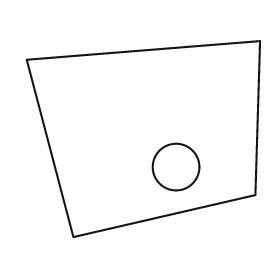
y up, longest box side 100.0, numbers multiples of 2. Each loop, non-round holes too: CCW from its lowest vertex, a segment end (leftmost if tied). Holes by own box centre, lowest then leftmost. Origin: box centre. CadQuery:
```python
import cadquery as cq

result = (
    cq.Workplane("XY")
    .moveTo(-30.0, -42.0)
    .lineTo(48.0, -24.0)
    .lineTo(50.0, 42.0)
    .lineTo(-50.0, 34.0)
    .close()
    .moveTo(14.0, -12.0)
    .circle(10.0)
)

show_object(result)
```